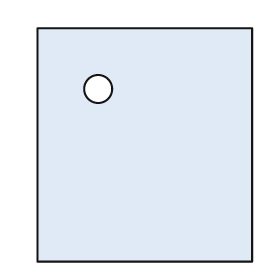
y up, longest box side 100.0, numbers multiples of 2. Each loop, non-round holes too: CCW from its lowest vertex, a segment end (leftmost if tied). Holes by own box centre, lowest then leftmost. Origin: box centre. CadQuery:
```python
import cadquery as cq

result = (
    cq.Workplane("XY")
    .moveTo(-46.0, -50.0)
    .lineTo(46.0, -50.0)
    .lineTo(46.0, 50.0)
    .lineTo(-46.0, 50.0)
    .close()
    .moveTo(-20.0, 24.0)
    .circle(6.0)
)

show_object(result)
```